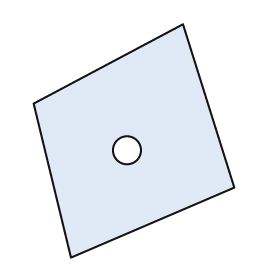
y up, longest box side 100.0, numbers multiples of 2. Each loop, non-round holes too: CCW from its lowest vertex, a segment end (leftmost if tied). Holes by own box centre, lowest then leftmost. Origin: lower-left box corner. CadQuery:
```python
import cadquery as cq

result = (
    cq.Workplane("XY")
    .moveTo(16.0, 0.0)
    .lineTo(86.0, 30.0)
    .lineTo(64.0, 100.0)
    .lineTo(0.0, 66.0)
    .close()
    .moveTo(40.0, 46.0)
    .circle(6.0)
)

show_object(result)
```